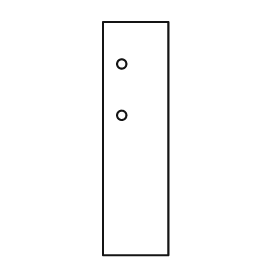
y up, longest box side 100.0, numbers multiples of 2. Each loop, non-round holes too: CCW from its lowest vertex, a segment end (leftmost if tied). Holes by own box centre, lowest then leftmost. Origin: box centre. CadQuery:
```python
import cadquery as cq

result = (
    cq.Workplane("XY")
    .moveTo(-14.0, -50.0)
    .lineTo(14.0, -50.0)
    .lineTo(14.0, 50.0)
    .lineTo(-14.0, 50.0)
    .close()
    .moveTo(-6.0, 10.0)
    .circle(2.0)
    .moveTo(-6.0, 32.0)
    .circle(2.0)
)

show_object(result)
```